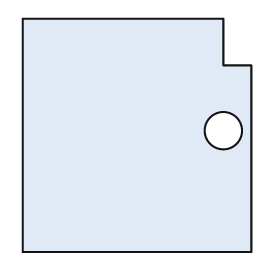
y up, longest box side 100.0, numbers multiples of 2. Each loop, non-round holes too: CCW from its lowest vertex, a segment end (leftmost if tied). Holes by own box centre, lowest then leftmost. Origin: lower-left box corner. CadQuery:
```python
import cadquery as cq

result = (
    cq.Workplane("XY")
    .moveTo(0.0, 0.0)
    .lineTo(98.0, 0.0)
    .lineTo(98.0, 80.0)
    .lineTo(86.0, 80.0)
    .lineTo(86.0, 100.0)
    .lineTo(0.0, 100.0)
    .close()
    .moveTo(86.0, 52.0)
    .circle(8.0)
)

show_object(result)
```